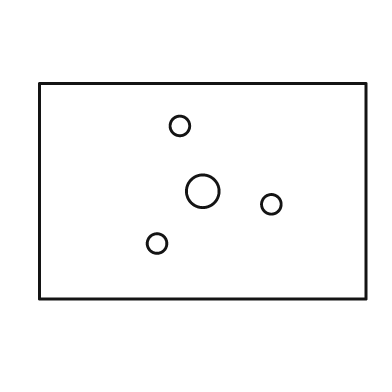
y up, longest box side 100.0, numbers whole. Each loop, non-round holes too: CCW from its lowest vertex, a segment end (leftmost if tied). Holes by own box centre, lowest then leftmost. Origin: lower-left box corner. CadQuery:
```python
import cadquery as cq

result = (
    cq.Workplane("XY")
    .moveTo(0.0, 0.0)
    .lineTo(100.0, 0.0)
    .lineTo(100.0, 66.0)
    .lineTo(0.0, 66.0)
    .close()
    .moveTo(36.0, 17.0)
    .circle(3.0)
    .moveTo(71.0, 29.0)
    .circle(3.0)
    .moveTo(50.0, 33.0)
    .circle(5.0)
    .moveTo(43.0, 53.0)
    .circle(3.0)
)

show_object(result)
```